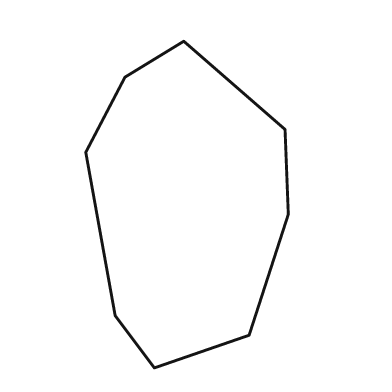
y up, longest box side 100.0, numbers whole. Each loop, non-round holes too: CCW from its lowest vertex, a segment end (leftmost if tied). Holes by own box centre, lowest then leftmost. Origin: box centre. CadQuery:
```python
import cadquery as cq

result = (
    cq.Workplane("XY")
    .moveTo(-10.0, -50.0)
    .lineTo(19.0, -40.0)
    .lineTo(31.0, -3.0)
    .lineTo(30.0, 23.0)
    .lineTo(-1.0, 50.0)
    .lineTo(-19.0, 39.0)
    .lineTo(-31.0, 16.0)
    .lineTo(-22.0, -34.0)
    .close()
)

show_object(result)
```